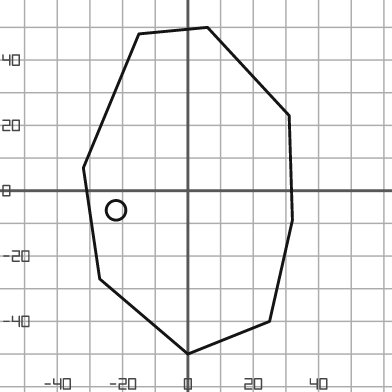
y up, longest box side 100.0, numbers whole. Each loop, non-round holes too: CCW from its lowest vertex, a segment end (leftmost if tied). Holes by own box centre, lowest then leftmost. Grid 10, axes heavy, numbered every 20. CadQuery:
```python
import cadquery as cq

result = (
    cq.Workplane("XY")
    .moveTo(0.0, -50.0)
    .lineTo(25.0, -40.0)
    .lineTo(32.0, -9.0)
    .lineTo(31.0, 23.0)
    .lineTo(6.0, 50.0)
    .lineTo(-15.0, 48.0)
    .lineTo(-32.0, 7.0)
    .lineTo(-27.0, -27.0)
    .close()
    .moveTo(-22.0, -6.0)
    .circle(3.0)
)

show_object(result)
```